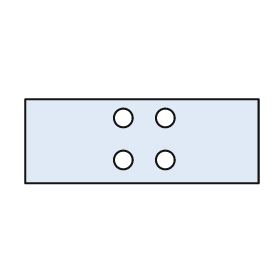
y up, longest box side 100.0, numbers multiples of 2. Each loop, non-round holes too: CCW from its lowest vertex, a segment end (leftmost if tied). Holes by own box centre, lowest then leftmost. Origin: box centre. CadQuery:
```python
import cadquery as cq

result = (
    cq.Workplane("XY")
    .moveTo(-50.0, -18.0)
    .lineTo(50.0, -18.0)
    .lineTo(50.0, 18.0)
    .lineTo(-50.0, 18.0)
    .close()
    .moveTo(-8.0, -8.0)
    .circle(4.0)
    .moveTo(10.0, -8.0)
    .circle(4.0)
    .moveTo(-8.0, 10.0)
    .circle(4.0)
    .moveTo(10.0, 10.0)
    .circle(4.0)
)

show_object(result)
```